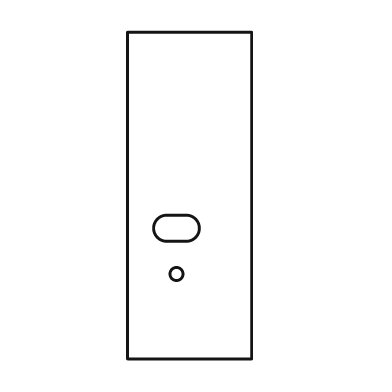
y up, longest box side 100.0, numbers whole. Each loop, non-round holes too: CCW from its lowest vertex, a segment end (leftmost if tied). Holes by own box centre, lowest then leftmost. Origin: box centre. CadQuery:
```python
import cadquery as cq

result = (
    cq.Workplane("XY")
    .moveTo(-19.0, -50.0)
    .lineTo(19.0, -50.0)
    .lineTo(19.0, 50.0)
    .lineTo(-19.0, 50.0)
    .close()
    .moveTo(-4.0, -24.0)
    .circle(2.0)
    .moveTo(-7.0, -14.0)
    .lineTo(-1.0, -14.0)
    .threePointArc((3.0, -10.0), (-1.0, -6.0))
    .lineTo(-7.0, -6.0)
    .threePointArc((-11.0, -10.0), (-7.0, -14.0))
    .close()
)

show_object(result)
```